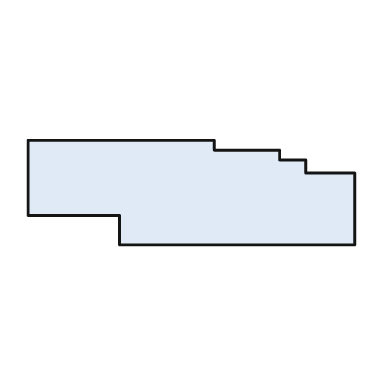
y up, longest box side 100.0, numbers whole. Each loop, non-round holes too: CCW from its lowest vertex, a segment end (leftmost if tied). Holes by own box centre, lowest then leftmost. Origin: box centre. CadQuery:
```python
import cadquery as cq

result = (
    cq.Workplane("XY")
    .moveTo(-22.0, -16.0)
    .lineTo(50.0, -16.0)
    .lineTo(50.0, 6.0)
    .lineTo(35.0, 6.0)
    .lineTo(35.0, 10.0)
    .lineTo(27.0, 10.0)
    .lineTo(27.0, 13.0)
    .lineTo(7.0, 13.0)
    .lineTo(7.0, 16.0)
    .lineTo(-50.0, 16.0)
    .lineTo(-50.0, -7.0)
    .lineTo(-22.0, -7.0)
    .close()
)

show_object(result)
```